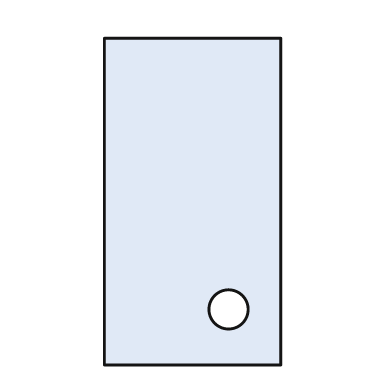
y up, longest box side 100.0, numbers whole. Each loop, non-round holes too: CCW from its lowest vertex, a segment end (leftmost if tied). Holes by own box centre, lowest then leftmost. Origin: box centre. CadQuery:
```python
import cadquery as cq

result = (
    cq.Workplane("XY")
    .moveTo(-27.0, -50.0)
    .lineTo(27.0, -50.0)
    .lineTo(27.0, 50.0)
    .lineTo(-27.0, 50.0)
    .close()
    .moveTo(11.0, -33.0)
    .circle(6.0)
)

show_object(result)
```